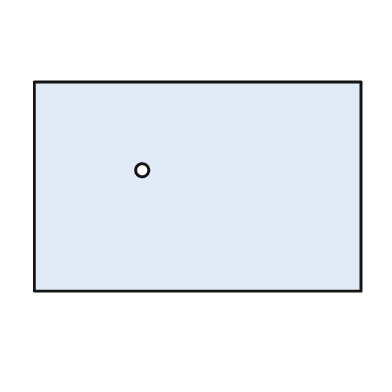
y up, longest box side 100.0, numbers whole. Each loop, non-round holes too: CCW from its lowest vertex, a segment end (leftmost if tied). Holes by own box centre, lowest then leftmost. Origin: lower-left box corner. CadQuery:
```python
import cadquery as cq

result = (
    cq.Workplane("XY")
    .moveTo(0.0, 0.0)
    .lineTo(100.0, 0.0)
    .lineTo(100.0, 64.0)
    .lineTo(0.0, 64.0)
    .close()
    .moveTo(33.0, 37.0)
    .circle(2.0)
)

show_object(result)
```